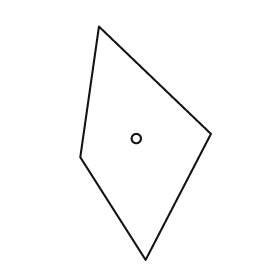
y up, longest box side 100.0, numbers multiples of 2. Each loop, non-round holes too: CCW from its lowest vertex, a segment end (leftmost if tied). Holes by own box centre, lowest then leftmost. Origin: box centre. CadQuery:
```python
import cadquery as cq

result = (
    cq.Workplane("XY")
    .moveTo(0.0, -50.0)
    .lineTo(28.0, 4.0)
    .lineTo(-20.0, 50.0)
    .lineTo(-28.0, -6.0)
    .close()
    .moveTo(-4.0, 2.0)
    .circle(2.0)
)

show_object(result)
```